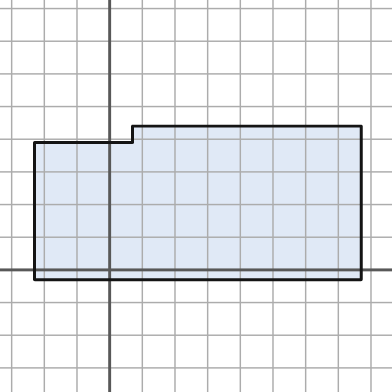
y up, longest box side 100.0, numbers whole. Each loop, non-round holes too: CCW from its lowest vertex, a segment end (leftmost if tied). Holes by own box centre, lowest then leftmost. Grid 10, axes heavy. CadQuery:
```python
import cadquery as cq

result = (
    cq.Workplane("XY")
    .moveTo(-23.0, -3.0)
    .lineTo(77.0, -3.0)
    .lineTo(77.0, 44.0)
    .lineTo(7.0, 44.0)
    .lineTo(7.0, 39.0)
    .lineTo(-23.0, 39.0)
    .close()
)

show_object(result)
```